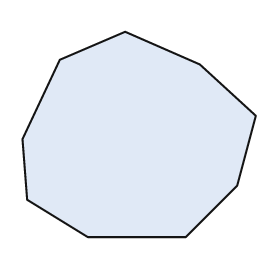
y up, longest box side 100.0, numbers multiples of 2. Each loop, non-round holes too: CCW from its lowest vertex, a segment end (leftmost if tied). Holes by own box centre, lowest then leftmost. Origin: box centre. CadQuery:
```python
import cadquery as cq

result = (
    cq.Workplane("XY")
    .moveTo(-22.0, -44.0)
    .lineTo(20.0, -44.0)
    .lineTo(42.0, -22.0)
    .lineTo(50.0, 8.0)
    .lineTo(26.0, 30.0)
    .lineTo(-6.0, 44.0)
    .lineTo(-34.0, 32.0)
    .lineTo(-50.0, -2.0)
    .lineTo(-48.0, -28.0)
    .close()
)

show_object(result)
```